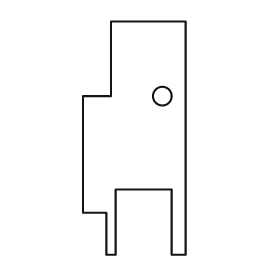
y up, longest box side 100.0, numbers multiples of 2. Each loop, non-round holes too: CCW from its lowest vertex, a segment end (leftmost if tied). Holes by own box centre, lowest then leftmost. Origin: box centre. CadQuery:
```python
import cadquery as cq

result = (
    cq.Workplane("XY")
    .moveTo(-12.0, -50.0)
    .lineTo(-8.0, -50.0)
    .lineTo(-8.0, -22.0)
    .lineTo(16.0, -22.0)
    .lineTo(16.0, -50.0)
    .lineTo(22.0, -50.0)
    .lineTo(22.0, 50.0)
    .lineTo(-10.0, 50.0)
    .lineTo(-10.0, 18.0)
    .lineTo(-22.0, 18.0)
    .lineTo(-22.0, -32.0)
    .lineTo(-12.0, -32.0)
    .close()
    .moveTo(12.0, 18.0)
    .circle(4.0)
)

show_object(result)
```